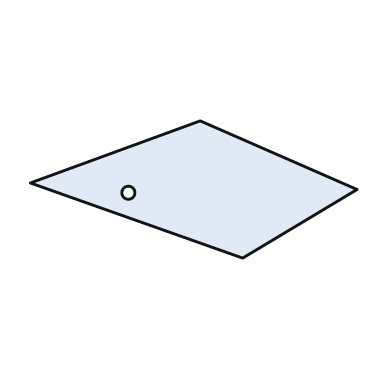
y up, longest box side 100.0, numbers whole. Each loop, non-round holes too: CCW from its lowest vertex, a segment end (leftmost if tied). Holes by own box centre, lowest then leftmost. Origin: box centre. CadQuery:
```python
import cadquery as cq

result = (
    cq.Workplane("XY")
    .moveTo(15.0, -21.0)
    .lineTo(50.0, 0.0)
    .lineTo(2.0, 21.0)
    .lineTo(-50.0, 2.0)
    .close()
    .moveTo(-20.0, -1.0)
    .circle(2.0)
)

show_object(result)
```